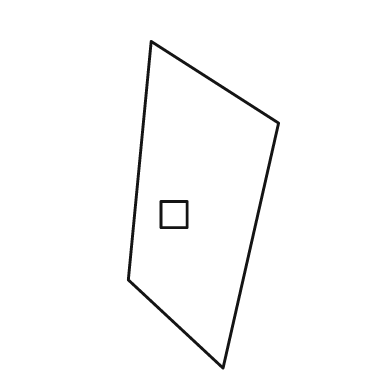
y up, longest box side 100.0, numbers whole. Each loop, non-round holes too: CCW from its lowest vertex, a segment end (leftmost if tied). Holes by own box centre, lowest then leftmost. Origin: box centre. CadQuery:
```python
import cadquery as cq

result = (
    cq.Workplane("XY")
    .moveTo(6.0, -50.0)
    .lineTo(23.0, 25.0)
    .lineTo(-16.0, 50.0)
    .lineTo(-23.0, -23.0)
    .close()
    .moveTo(-13.0, -7.0)
    .lineTo(-5.0, -7.0)
    .lineTo(-5.0, 1.0)
    .lineTo(-13.0, 1.0)
    .close()
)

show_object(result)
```